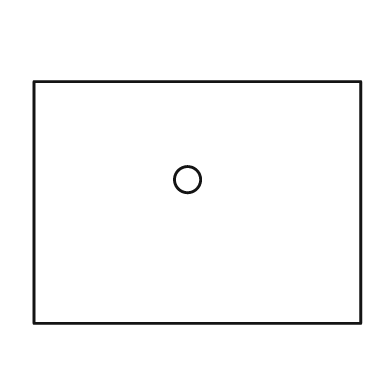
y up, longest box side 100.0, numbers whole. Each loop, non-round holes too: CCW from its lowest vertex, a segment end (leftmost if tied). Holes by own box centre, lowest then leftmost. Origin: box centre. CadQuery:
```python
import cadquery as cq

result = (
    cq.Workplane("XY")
    .moveTo(-50.0, -37.0)
    .lineTo(50.0, -37.0)
    .lineTo(50.0, 37.0)
    .lineTo(-50.0, 37.0)
    .close()
    .moveTo(-3.0, 7.0)
    .circle(4.0)
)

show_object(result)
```